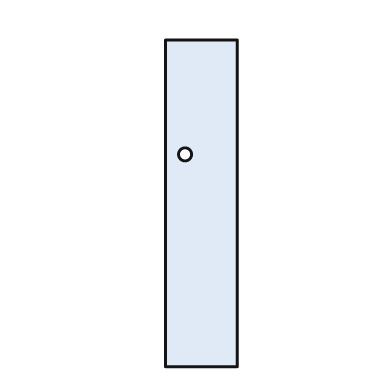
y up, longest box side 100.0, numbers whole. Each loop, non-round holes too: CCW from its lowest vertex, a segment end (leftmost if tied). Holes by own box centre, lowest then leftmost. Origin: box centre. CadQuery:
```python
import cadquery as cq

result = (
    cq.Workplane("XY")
    .moveTo(-11.0, -50.0)
    .lineTo(11.0, -50.0)
    .lineTo(11.0, 50.0)
    .lineTo(-11.0, 50.0)
    .close()
    .moveTo(-5.0, 15.0)
    .circle(2.0)
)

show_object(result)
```